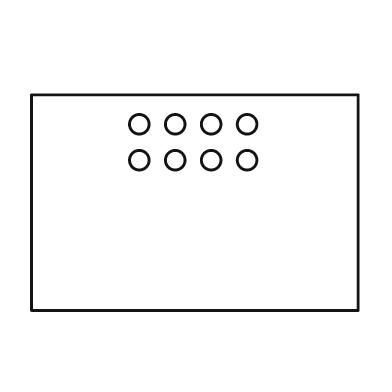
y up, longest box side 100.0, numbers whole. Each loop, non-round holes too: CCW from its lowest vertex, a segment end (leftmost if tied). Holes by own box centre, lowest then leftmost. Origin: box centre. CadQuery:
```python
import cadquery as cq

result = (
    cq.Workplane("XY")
    .moveTo(-50.0, -33.0)
    .lineTo(50.0, -33.0)
    .lineTo(50.0, 33.0)
    .lineTo(-50.0, 33.0)
    .close()
    .moveTo(-17.0, 13.0)
    .circle(3.0)
    .moveTo(-6.0, 13.0)
    .circle(3.0)
    .moveTo(5.0, 13.0)
    .circle(3.0)
    .moveTo(16.0, 13.0)
    .circle(3.0)
    .moveTo(-17.0, 24.0)
    .circle(3.0)
    .moveTo(-6.0, 24.0)
    .circle(3.0)
    .moveTo(5.0, 24.0)
    .circle(3.0)
    .moveTo(16.0, 24.0)
    .circle(3.0)
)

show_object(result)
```